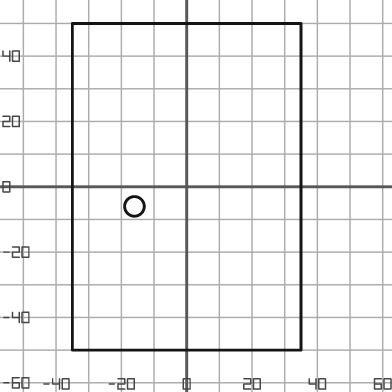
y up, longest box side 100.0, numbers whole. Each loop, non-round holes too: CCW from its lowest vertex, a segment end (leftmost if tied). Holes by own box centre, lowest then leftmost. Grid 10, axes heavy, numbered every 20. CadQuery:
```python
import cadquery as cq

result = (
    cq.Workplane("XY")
    .moveTo(-35.0, -50.0)
    .lineTo(35.0, -50.0)
    .lineTo(35.0, 50.0)
    .lineTo(-35.0, 50.0)
    .close()
    .moveTo(-16.0, -6.0)
    .circle(3.0)
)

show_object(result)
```